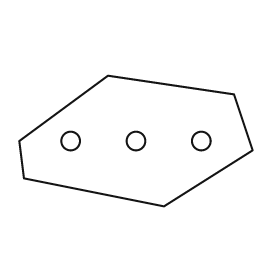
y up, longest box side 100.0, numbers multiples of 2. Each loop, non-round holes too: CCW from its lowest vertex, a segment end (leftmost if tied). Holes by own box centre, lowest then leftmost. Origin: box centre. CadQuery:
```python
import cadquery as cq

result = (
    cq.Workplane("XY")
    .moveTo(12.0, -28.0)
    .lineTo(50.0, -4.0)
    .lineTo(42.0, 20.0)
    .lineTo(-12.0, 28.0)
    .lineTo(-50.0, 0.0)
    .lineTo(-48.0, -16.0)
    .close()
    .moveTo(-28.0, 0.0)
    .circle(4.0)
    .moveTo(0.0, 0.0)
    .circle(4.0)
    .moveTo(28.0, 0.0)
    .circle(4.0)
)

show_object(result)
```